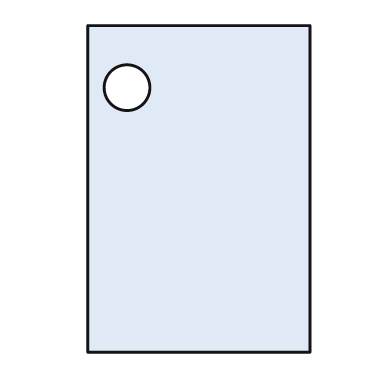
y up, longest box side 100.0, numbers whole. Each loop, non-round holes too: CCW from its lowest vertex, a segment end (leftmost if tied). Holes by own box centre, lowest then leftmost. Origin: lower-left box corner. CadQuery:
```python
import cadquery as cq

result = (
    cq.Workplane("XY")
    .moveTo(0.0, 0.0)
    .lineTo(68.0, 0.0)
    .lineTo(68.0, 100.0)
    .lineTo(0.0, 100.0)
    .close()
    .moveTo(12.0, 81.0)
    .circle(7.0)
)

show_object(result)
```